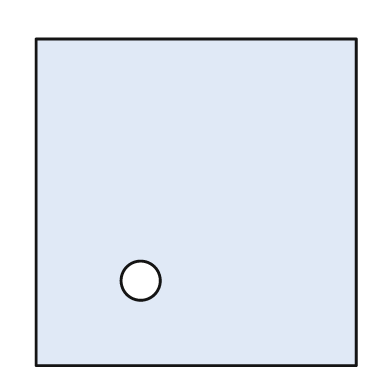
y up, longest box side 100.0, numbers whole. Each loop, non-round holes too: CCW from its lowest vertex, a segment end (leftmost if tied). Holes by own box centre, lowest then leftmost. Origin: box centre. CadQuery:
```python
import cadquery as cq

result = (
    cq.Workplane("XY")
    .moveTo(-49.0, -50.0)
    .lineTo(49.0, -50.0)
    .lineTo(49.0, 50.0)
    .lineTo(-49.0, 50.0)
    .close()
    .moveTo(-17.0, -24.0)
    .circle(6.0)
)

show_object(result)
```